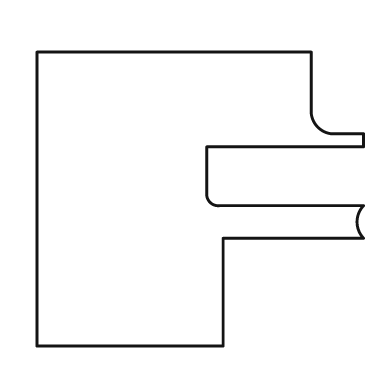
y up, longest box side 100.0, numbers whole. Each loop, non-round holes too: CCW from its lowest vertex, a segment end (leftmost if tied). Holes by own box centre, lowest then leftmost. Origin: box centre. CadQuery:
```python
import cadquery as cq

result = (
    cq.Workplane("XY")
    .moveTo(-50.0, -45.0)
    .lineTo(7.0, -45.0)
    .lineTo(7.0, -12.0)
    .lineTo(50.0, -12.0)
    .threePointArc((48.0, -7.0), (50.0, -2.0))
    .lineTo(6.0, -2.0)
    .threePointArc((3.0, -1.0), (2.0, 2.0))
    .lineTo(2.0, 16.0)
    .lineTo(50.0, 16.0)
    .lineTo(50.0, 20.0)
    .lineTo(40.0, 20.0)
    .threePointArc((36.0, 22.0), (34.0, 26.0))
    .lineTo(34.0, 45.0)
    .lineTo(-50.0, 45.0)
    .close()
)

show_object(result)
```